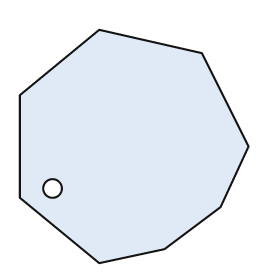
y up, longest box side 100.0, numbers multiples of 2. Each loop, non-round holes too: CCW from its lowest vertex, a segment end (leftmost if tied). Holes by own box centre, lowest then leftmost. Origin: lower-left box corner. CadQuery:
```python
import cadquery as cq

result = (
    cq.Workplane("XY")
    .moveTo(34.0, 0.0)
    .lineTo(62.0, 6.0)
    .lineTo(86.0, 24.0)
    .lineTo(98.0, 50.0)
    .lineTo(78.0, 90.0)
    .lineTo(34.0, 100.0)
    .lineTo(0.0, 72.0)
    .lineTo(0.0, 28.0)
    .close()
    .moveTo(14.0, 32.0)
    .circle(4.0)
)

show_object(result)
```